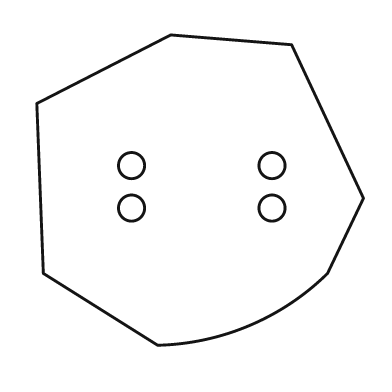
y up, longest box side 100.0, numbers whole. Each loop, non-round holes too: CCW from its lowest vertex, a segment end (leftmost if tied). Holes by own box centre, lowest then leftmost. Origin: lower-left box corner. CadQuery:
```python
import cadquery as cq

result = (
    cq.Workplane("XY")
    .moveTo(37.0, 0.0)
    .threePointArc((65.0, 6.0), (89.0, 22.0))
    .lineTo(100.0, 45.0)
    .lineTo(78.0, 92.0)
    .lineTo(41.0, 95.0)
    .lineTo(0.0, 74.0)
    .lineTo(2.0, 22.0)
    .close()
    .moveTo(29.0, 42.0)
    .circle(4.0)
    .moveTo(72.0, 42.0)
    .circle(4.0)
    .moveTo(29.0, 55.0)
    .circle(4.0)
    .moveTo(72.0, 55.0)
    .circle(4.0)
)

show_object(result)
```